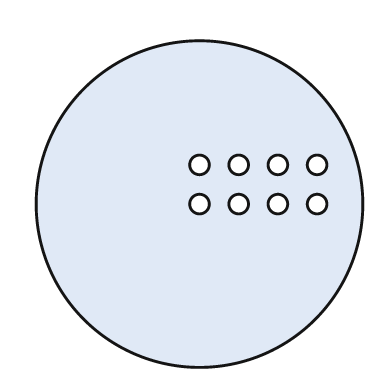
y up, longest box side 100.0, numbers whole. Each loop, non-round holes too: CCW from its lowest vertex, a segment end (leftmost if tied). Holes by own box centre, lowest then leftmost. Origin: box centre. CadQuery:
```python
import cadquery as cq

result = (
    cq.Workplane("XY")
    .moveTo(0.0, 0.0)
    .circle(50.0)
    .moveTo(0.0, 0.0)
    .circle(3.0)
    .moveTo(12.0, 0.0)
    .circle(3.0)
    .moveTo(24.0, 0.0)
    .circle(3.0)
    .moveTo(36.0, 0.0)
    .circle(3.0)
    .moveTo(0.0, 12.0)
    .circle(3.0)
    .moveTo(12.0, 12.0)
    .circle(3.0)
    .moveTo(24.0, 12.0)
    .circle(3.0)
    .moveTo(36.0, 12.0)
    .circle(3.0)
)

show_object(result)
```